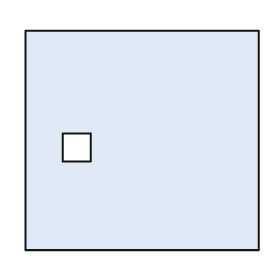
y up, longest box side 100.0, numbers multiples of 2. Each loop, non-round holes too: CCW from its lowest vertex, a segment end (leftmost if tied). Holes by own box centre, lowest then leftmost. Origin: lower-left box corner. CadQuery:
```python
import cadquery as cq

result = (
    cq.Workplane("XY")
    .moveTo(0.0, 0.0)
    .lineTo(100.0, 0.0)
    .lineTo(100.0, 94.0)
    .lineTo(0.0, 94.0)
    .close()
    .moveTo(16.0, 38.0)
    .lineTo(28.0, 38.0)
    .lineTo(28.0, 50.0)
    .lineTo(16.0, 50.0)
    .close()
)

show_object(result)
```